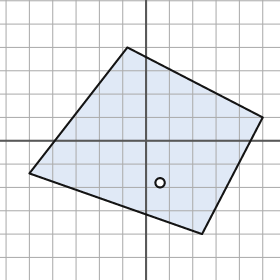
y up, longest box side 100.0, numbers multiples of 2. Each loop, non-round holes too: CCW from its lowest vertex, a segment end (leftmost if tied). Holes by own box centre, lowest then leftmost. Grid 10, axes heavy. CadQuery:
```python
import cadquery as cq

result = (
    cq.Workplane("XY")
    .moveTo(24.0, -40.0)
    .lineTo(50.0, 10.0)
    .lineTo(-8.0, 40.0)
    .lineTo(-50.0, -14.0)
    .close()
    .moveTo(6.0, -18.0)
    .circle(2.0)
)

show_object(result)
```